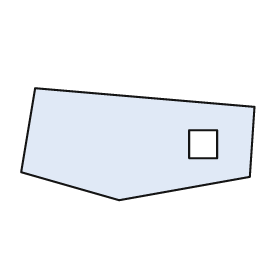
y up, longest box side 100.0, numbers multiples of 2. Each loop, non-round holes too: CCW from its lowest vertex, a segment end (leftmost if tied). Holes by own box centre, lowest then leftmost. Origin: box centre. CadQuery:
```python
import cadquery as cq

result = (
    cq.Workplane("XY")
    .moveTo(-8.0, -24.0)
    .lineTo(48.0, -14.0)
    .lineTo(50.0, 16.0)
    .lineTo(-44.0, 24.0)
    .lineTo(-50.0, -12.0)
    .close()
    .moveTo(22.0, -6.0)
    .lineTo(34.0, -6.0)
    .lineTo(34.0, 6.0)
    .lineTo(22.0, 6.0)
    .close()
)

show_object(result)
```